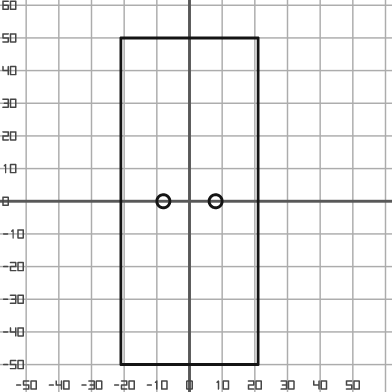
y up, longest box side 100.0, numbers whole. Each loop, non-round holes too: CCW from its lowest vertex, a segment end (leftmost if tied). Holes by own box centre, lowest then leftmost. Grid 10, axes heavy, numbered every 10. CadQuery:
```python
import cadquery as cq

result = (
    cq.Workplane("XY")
    .moveTo(-21.0, -50.0)
    .lineTo(21.0, -50.0)
    .lineTo(21.0, 50.0)
    .lineTo(-21.0, 50.0)
    .close()
    .moveTo(-8.0, 0.0)
    .circle(2.0)
    .moveTo(8.0, 0.0)
    .circle(2.0)
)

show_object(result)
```